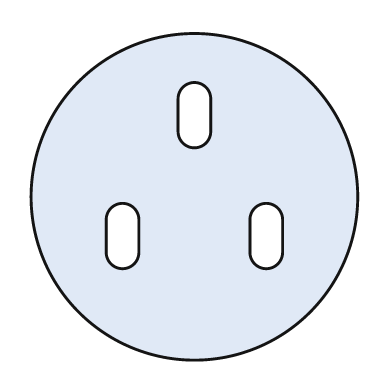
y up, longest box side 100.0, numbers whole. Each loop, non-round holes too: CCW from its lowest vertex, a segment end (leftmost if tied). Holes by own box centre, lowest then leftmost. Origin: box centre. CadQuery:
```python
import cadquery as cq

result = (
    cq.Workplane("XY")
    .moveTo(0.0, 0.0)
    .circle(50.0)
    .moveTo(-27.0, -17.0)
    .threePointArc((-22.0, -22.0), (-17.0, -17.0))
    .lineTo(-17.0, -7.0)
    .threePointArc((-22.0, -2.0), (-27.0, -7.0))
    .close()
    .moveTo(17.0, -17.0)
    .threePointArc((22.0, -22.0), (27.0, -17.0))
    .lineTo(27.0, -7.0)
    .threePointArc((22.0, -2.0), (17.0, -7.0))
    .close()
    .moveTo(-5.0, 20.0)
    .threePointArc((0.0, 15.0), (5.0, 20.0))
    .lineTo(5.0, 30.0)
    .threePointArc((0.0, 35.0), (-5.0, 30.0))
    .close()
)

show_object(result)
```